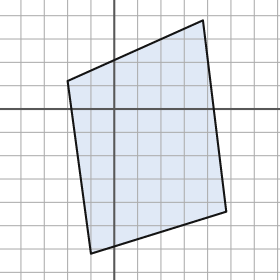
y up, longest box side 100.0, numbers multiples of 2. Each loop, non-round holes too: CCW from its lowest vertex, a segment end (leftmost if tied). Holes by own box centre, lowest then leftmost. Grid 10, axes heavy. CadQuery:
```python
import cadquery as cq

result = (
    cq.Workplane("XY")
    .moveTo(-10.0, -62.0)
    .lineTo(48.0, -44.0)
    .lineTo(38.0, 38.0)
    .lineTo(-20.0, 12.0)
    .close()
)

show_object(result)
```